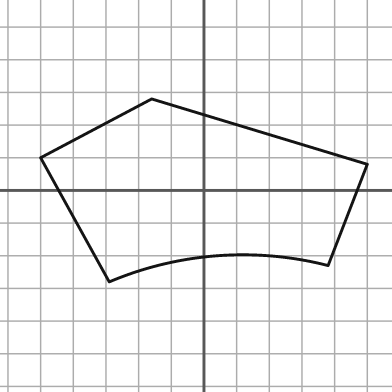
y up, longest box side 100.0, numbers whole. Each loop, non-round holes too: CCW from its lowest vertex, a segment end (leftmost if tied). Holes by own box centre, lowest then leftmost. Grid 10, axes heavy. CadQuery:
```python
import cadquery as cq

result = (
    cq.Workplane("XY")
    .moveTo(-29.0, -28.0)
    .threePointArc((4.0, -20.0), (38.0, -23.0))
    .lineTo(50.0, 8.0)
    .lineTo(-16.0, 28.0)
    .lineTo(-50.0, 10.0)
    .close()
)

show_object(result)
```